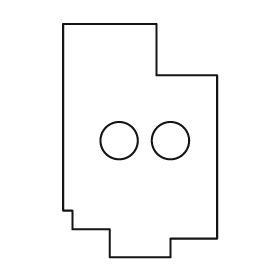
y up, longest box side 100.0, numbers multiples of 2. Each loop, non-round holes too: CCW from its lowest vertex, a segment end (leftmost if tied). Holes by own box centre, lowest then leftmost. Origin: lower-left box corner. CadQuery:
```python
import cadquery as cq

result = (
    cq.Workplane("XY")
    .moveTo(20.0, 0.0)
    .lineTo(46.0, 0.0)
    .lineTo(46.0, 8.0)
    .lineTo(66.0, 8.0)
    .lineTo(66.0, 78.0)
    .lineTo(40.0, 78.0)
    .lineTo(40.0, 100.0)
    .lineTo(0.0, 100.0)
    .lineTo(0.0, 20.0)
    .lineTo(4.0, 20.0)
    .lineTo(4.0, 12.0)
    .lineTo(20.0, 12.0)
    .close()
    .moveTo(24.0, 50.0)
    .circle(8.0)
    .moveTo(46.0, 50.0)
    .circle(8.0)
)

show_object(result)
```